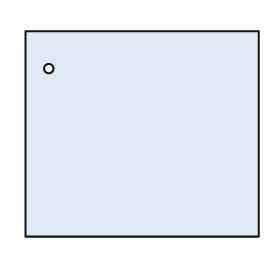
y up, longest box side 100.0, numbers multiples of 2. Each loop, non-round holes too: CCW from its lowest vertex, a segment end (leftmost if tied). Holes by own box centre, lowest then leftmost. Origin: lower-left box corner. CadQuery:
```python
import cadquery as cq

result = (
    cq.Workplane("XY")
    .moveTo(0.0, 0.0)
    .lineTo(100.0, 0.0)
    .lineTo(100.0, 88.0)
    .lineTo(0.0, 88.0)
    .close()
    .moveTo(10.0, 72.0)
    .circle(2.0)
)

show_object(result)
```